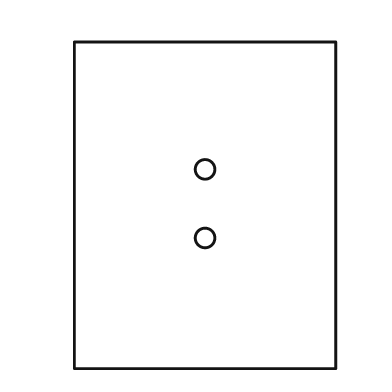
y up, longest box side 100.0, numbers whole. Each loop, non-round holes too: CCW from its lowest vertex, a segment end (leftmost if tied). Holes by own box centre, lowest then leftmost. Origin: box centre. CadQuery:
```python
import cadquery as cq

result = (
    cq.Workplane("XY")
    .moveTo(-40.0, -50.0)
    .lineTo(40.0, -50.0)
    .lineTo(40.0, 50.0)
    .lineTo(-40.0, 50.0)
    .close()
    .moveTo(0.0, -10.0)
    .circle(3.0)
    .moveTo(0.0, 11.0)
    .circle(3.0)
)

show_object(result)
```